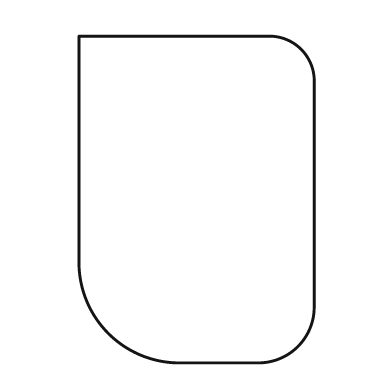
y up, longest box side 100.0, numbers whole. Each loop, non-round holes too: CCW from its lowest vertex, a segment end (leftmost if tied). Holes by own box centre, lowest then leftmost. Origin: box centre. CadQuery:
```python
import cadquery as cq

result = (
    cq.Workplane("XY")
    .moveTo(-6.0, -50.0)
    .lineTo(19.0, -50.0)
    .threePointArc((31.0, -45.0), (36.0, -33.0))
    .lineTo(36.0, 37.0)
    .threePointArc((32.0, 46.0), (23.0, 50.0))
    .lineTo(-36.0, 50.0)
    .lineTo(-36.0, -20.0)
    .threePointArc((-27.0, -41.0), (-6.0, -50.0))
    .close()
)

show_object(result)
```